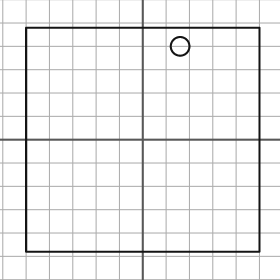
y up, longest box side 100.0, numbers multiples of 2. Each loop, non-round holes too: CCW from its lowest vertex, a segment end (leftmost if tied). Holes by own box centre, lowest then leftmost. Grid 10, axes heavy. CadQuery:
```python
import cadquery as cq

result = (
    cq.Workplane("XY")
    .moveTo(-50.0, -48.0)
    .lineTo(50.0, -48.0)
    .lineTo(50.0, 48.0)
    .lineTo(-50.0, 48.0)
    .close()
    .moveTo(16.0, 40.0)
    .circle(4.0)
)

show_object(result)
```